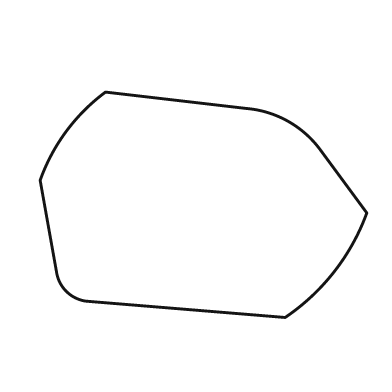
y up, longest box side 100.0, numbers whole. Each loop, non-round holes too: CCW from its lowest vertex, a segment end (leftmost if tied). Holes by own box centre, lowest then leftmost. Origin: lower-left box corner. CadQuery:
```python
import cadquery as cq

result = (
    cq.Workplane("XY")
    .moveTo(75.0, 0.0)
    .threePointArc((90.0, 14.0), (100.0, 32.0))
    .lineTo(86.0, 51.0)
    .threePointArc((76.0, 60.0), (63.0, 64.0))
    .lineTo(20.0, 69.0)
    .threePointArc((8.0, 57.0), (0.0, 42.0))
    .lineTo(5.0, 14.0)
    .threePointArc((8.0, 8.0), (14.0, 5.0))
    .close()
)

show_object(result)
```